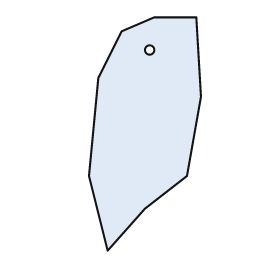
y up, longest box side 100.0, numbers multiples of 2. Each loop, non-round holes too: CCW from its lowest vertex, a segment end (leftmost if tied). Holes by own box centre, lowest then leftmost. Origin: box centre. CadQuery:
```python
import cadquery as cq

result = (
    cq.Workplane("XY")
    .moveTo(-16.0, -50.0)
    .lineTo(0.0, -32.0)
    .lineTo(18.0, -18.0)
    .lineTo(24.0, 16.0)
    .lineTo(22.0, 50.0)
    .lineTo(4.0, 50.0)
    .lineTo(-10.0, 44.0)
    .lineTo(-20.0, 24.0)
    .lineTo(-24.0, -18.0)
    .close()
    .moveTo(2.0, 36.0)
    .circle(2.0)
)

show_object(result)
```